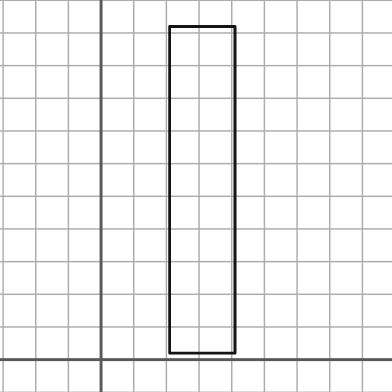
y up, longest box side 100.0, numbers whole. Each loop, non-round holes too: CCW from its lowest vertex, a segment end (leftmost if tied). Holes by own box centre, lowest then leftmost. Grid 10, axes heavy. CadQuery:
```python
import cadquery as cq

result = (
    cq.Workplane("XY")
    .moveTo(21.0, 2.0)
    .lineTo(41.0, 2.0)
    .lineTo(41.0, 102.0)
    .lineTo(21.0, 102.0)
    .close()
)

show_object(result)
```